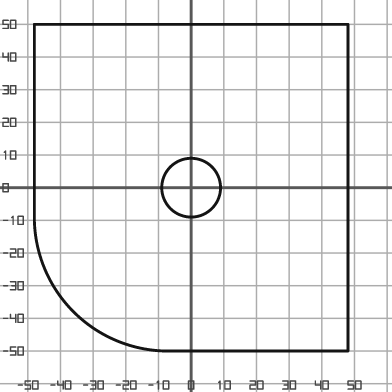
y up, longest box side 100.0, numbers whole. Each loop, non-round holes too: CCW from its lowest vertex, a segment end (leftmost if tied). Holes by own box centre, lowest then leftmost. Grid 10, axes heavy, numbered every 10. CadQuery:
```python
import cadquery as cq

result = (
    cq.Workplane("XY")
    .moveTo(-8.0, -50.0)
    .lineTo(48.0, -50.0)
    .lineTo(48.0, 50.0)
    .lineTo(-48.0, 50.0)
    .lineTo(-48.0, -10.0)
    .threePointArc((-36.0, -38.0), (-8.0, -50.0))
    .close()
    .moveTo(0.0, 0.0)
    .circle(9.0)
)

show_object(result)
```